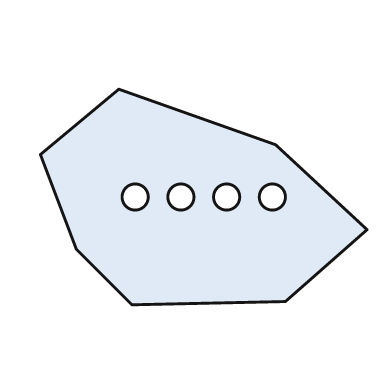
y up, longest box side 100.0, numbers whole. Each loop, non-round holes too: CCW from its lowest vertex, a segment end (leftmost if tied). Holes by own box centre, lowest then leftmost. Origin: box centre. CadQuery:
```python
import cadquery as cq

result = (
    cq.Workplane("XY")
    .moveTo(-22.0, -33.0)
    .lineTo(25.0, -32.0)
    .lineTo(50.0, -10.0)
    .lineTo(22.0, 16.0)
    .lineTo(-26.0, 33.0)
    .lineTo(-50.0, 13.0)
    .lineTo(-39.0, -16.0)
    .close()
    .moveTo(-21.0, 0.0)
    .circle(4.0)
    .moveTo(-7.0, 0.0)
    .circle(4.0)
    .moveTo(7.0, 0.0)
    .circle(4.0)
    .moveTo(21.0, 0.0)
    .circle(4.0)
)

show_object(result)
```